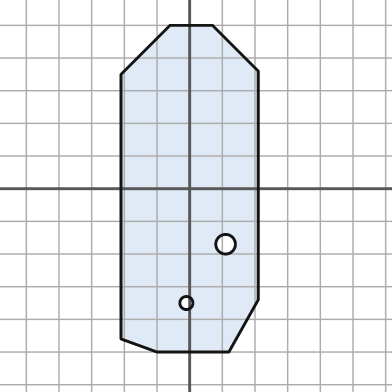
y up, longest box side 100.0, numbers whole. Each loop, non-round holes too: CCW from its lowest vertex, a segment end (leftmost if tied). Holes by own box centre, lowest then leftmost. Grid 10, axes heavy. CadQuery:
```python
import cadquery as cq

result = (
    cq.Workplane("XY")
    .moveTo(-10.0, -50.0)
    .lineTo(12.0, -50.0)
    .lineTo(21.0, -34.0)
    .lineTo(21.0, 36.0)
    .lineTo(7.0, 50.0)
    .lineTo(-6.0, 50.0)
    .lineTo(-21.0, 35.0)
    .lineTo(-21.0, -46.0)
    .close()
    .moveTo(-1.0, -35.0)
    .circle(2.0)
    .moveTo(11.0, -17.0)
    .circle(3.0)
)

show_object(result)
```